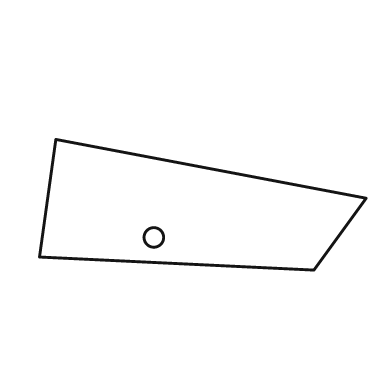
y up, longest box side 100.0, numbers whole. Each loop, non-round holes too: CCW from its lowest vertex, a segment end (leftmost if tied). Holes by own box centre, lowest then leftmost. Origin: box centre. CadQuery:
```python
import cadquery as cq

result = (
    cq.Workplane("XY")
    .moveTo(34.0, -20.0)
    .lineTo(50.0, 2.0)
    .lineTo(-45.0, 20.0)
    .lineTo(-50.0, -16.0)
    .close()
    .moveTo(-15.0, -10.0)
    .circle(3.0)
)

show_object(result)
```